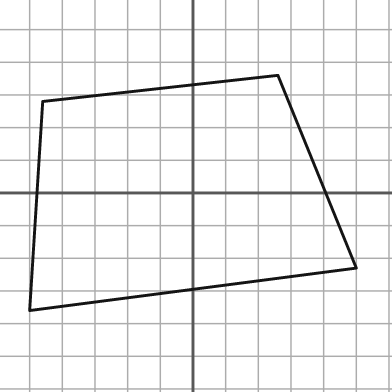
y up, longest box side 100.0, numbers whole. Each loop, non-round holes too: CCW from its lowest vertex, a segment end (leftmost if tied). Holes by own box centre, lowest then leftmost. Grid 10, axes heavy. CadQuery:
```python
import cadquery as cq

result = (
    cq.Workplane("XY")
    .moveTo(-50.0, -36.0)
    .lineTo(50.0, -23.0)
    .lineTo(26.0, 36.0)
    .lineTo(-46.0, 28.0)
    .close()
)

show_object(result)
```